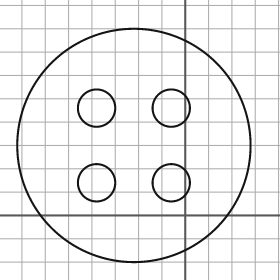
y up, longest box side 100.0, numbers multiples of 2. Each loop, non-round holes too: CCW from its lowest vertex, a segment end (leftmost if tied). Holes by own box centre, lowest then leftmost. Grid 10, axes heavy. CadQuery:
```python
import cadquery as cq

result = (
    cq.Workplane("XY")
    .moveTo(-22.0, 30.0)
    .circle(50.0)
    .moveTo(-38.0, 14.0)
    .circle(8.0)
    .moveTo(-6.0, 14.0)
    .circle(8.0)
    .moveTo(-38.0, 46.0)
    .circle(8.0)
    .moveTo(-6.0, 46.0)
    .circle(8.0)
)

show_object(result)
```